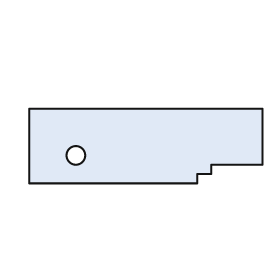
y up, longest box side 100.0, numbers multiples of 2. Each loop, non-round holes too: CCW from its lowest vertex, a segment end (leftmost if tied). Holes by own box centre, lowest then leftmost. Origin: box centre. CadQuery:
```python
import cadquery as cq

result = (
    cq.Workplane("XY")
    .moveTo(-50.0, -16.0)
    .lineTo(22.0, -16.0)
    .lineTo(22.0, -12.0)
    .lineTo(28.0, -12.0)
    .lineTo(28.0, -8.0)
    .lineTo(50.0, -8.0)
    .lineTo(50.0, 16.0)
    .lineTo(-50.0, 16.0)
    .close()
    .moveTo(-30.0, -4.0)
    .circle(4.0)
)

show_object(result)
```